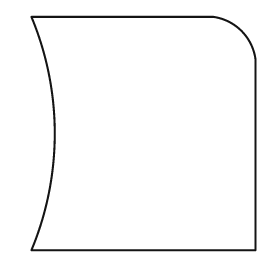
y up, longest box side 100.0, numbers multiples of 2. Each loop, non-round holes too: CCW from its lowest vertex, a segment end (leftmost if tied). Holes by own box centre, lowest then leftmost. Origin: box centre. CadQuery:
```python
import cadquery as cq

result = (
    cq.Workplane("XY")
    .moveTo(-48.0, -50.0)
    .lineTo(48.0, -50.0)
    .lineTo(48.0, 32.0)
    .threePointArc((42.0, 44.0), (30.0, 50.0))
    .lineTo(-48.0, 50.0)
    .threePointArc((-38.0, 0.0), (-48.0, -50.0))
    .close()
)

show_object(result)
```